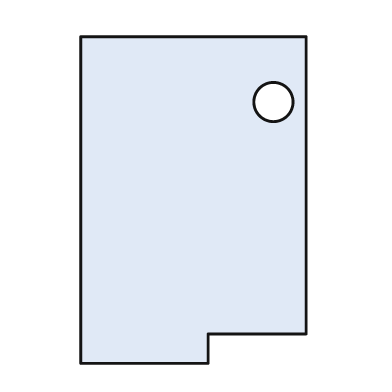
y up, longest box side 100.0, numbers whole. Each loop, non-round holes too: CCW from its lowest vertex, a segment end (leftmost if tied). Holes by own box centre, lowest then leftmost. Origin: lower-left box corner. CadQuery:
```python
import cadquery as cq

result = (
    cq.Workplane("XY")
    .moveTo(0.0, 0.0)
    .lineTo(39.0, 0.0)
    .lineTo(39.0, 9.0)
    .lineTo(69.0, 9.0)
    .lineTo(69.0, 100.0)
    .lineTo(0.0, 100.0)
    .close()
    .moveTo(59.0, 80.0)
    .circle(6.0)
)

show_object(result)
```